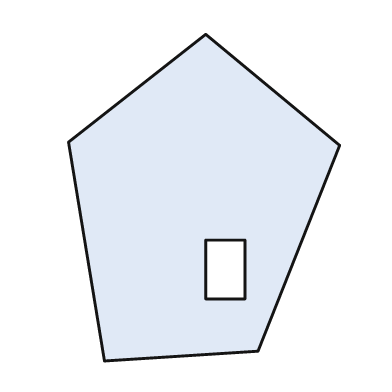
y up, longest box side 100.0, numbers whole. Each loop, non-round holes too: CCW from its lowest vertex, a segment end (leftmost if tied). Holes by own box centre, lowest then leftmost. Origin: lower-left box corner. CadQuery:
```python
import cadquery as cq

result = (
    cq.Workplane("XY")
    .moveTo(11.0, 0.0)
    .lineTo(58.0, 3.0)
    .lineTo(83.0, 66.0)
    .lineTo(42.0, 100.0)
    .lineTo(0.0, 67.0)
    .close()
    .moveTo(42.0, 19.0)
    .lineTo(54.0, 19.0)
    .lineTo(54.0, 37.0)
    .lineTo(42.0, 37.0)
    .close()
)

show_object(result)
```